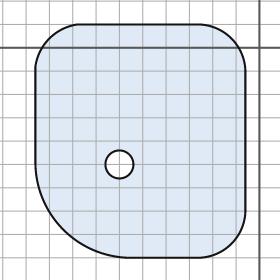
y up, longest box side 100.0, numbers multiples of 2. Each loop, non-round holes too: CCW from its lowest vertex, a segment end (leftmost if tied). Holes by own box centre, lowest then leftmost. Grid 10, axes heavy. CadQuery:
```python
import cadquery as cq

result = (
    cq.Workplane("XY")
    .moveTo(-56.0, -90.0)
    .lineTo(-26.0, -90.0)
    .threePointArc((-12.0, -84.0), (-6.0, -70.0))
    .lineTo(-6.0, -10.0)
    .threePointArc((-12.0, 4.0), (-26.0, 10.0))
    .lineTo(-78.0, 10.0)
    .threePointArc((-90.0, 4.0), (-96.0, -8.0))
    .lineTo(-96.0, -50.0)
    .threePointArc((-84.0, -78.0), (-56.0, -90.0))
    .close()
    .moveTo(-60.0, -50.0)
    .circle(6.0)
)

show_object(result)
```